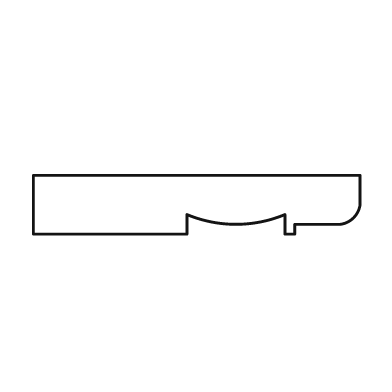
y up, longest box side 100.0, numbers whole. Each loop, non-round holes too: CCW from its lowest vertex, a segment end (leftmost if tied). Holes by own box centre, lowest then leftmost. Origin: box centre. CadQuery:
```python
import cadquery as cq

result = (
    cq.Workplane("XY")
    .moveTo(-50.0, -9.0)
    .lineTo(-3.0, -9.0)
    .lineTo(-3.0, -3.0)
    .threePointArc((12.0, -6.0), (27.0, -3.0))
    .lineTo(27.0, -9.0)
    .lineTo(30.0, -9.0)
    .lineTo(30.0, -6.0)
    .lineTo(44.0, -6.0)
    .threePointArc((48.0, -4.0), (50.0, 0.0))
    .lineTo(50.0, 9.0)
    .lineTo(-50.0, 9.0)
    .close()
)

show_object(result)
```